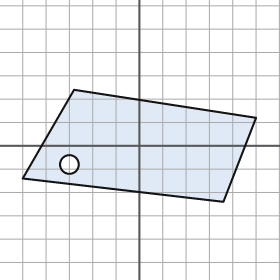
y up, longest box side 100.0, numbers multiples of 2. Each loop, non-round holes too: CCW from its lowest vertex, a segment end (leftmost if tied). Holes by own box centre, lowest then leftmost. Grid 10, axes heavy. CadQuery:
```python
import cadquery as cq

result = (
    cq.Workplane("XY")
    .moveTo(36.0, -24.0)
    .lineTo(50.0, 12.0)
    .lineTo(-28.0, 24.0)
    .lineTo(-50.0, -14.0)
    .close()
    .moveTo(-30.0, -8.0)
    .circle(4.0)
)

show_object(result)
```